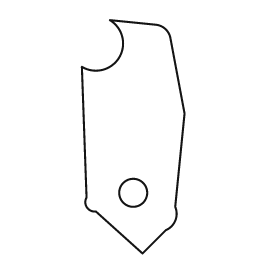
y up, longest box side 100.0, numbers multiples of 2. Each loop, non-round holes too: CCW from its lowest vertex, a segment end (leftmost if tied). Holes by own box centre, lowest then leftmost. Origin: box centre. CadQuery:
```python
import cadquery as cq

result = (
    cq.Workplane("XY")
    .moveTo(4.0, -50.0)
    .lineTo(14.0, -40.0)
    .threePointArc((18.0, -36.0), (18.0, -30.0))
    .lineTo(22.0, 10.0)
    .lineTo(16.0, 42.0)
    .threePointArc((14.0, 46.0), (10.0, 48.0))
    .lineTo(-10.0, 50.0)
    .threePointArc((-6.0, 34.0), (-22.0, 30.0))
    .lineTo(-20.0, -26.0)
    .threePointArc((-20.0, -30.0), (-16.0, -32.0))
    .close()
    .moveTo(0.0, -24.0)
    .circle(6.0)
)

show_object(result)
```